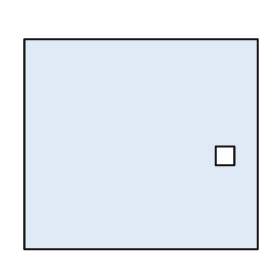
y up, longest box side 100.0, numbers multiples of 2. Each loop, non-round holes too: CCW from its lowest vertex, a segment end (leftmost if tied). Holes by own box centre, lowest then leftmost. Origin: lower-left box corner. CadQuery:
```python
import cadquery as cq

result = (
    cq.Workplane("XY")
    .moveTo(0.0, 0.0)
    .lineTo(100.0, 0.0)
    .lineTo(100.0, 90.0)
    .lineTo(0.0, 90.0)
    .close()
    .moveTo(82.0, 36.0)
    .lineTo(90.0, 36.0)
    .lineTo(90.0, 44.0)
    .lineTo(82.0, 44.0)
    .close()
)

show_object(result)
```